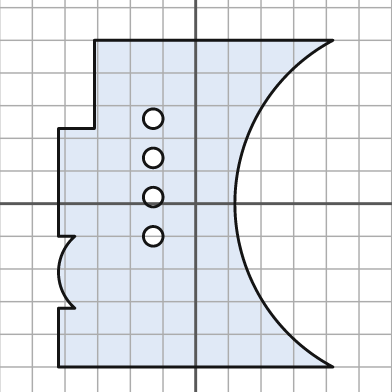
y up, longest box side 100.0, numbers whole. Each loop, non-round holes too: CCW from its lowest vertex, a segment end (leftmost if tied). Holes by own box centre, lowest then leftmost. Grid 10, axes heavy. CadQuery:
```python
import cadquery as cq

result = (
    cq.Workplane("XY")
    .moveTo(-42.0, -50.0)
    .lineTo(42.0, -50.0)
    .threePointArc((12.0, 0.0), (42.0, 50.0))
    .lineTo(-31.0, 50.0)
    .lineTo(-31.0, 23.0)
    .lineTo(-42.0, 23.0)
    .lineTo(-42.0, -10.0)
    .lineTo(-37.0, -10.0)
    .threePointArc((-42.0, -21.0), (-37.0, -32.0))
    .lineTo(-42.0, -32.0)
    .close()
    .moveTo(-13.0, -10.0)
    .circle(3.0)
    .moveTo(-13.0, 2.0)
    .circle(3.0)
    .moveTo(-13.0, 14.0)
    .circle(3.0)
    .moveTo(-13.0, 26.0)
    .circle(3.0)
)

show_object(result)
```